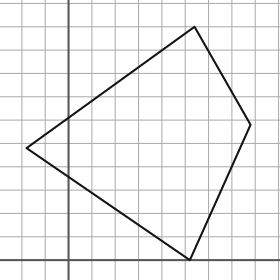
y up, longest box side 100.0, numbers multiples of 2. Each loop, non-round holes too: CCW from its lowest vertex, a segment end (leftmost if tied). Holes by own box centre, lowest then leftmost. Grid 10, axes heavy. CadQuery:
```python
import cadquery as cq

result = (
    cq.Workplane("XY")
    .moveTo(52.0, 0.0)
    .lineTo(78.0, 58.0)
    .lineTo(54.0, 100.0)
    .lineTo(-18.0, 48.0)
    .close()
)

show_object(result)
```